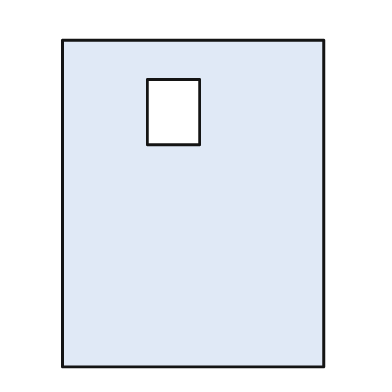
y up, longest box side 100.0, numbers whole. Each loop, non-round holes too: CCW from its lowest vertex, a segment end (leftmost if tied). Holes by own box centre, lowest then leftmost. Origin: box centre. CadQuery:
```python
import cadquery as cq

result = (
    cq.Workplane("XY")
    .moveTo(-40.0, -50.0)
    .lineTo(40.0, -50.0)
    .lineTo(40.0, 50.0)
    .lineTo(-40.0, 50.0)
    .close()
    .moveTo(-14.0, 18.0)
    .lineTo(2.0, 18.0)
    .lineTo(2.0, 38.0)
    .lineTo(-14.0, 38.0)
    .close()
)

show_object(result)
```